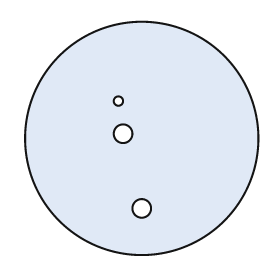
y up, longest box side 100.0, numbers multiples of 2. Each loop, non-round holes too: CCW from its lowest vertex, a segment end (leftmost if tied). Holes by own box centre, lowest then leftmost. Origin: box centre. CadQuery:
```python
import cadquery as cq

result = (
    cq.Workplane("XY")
    .moveTo(0.0, 0.0)
    .circle(50.0)
    .moveTo(0.0, -30.0)
    .circle(4.0)
    .moveTo(-8.0, 2.0)
    .circle(4.0)
    .moveTo(-10.0, 16.0)
    .circle(2.0)
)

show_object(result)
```